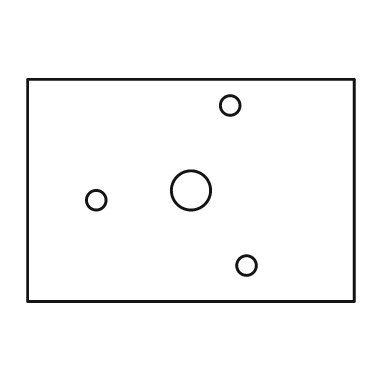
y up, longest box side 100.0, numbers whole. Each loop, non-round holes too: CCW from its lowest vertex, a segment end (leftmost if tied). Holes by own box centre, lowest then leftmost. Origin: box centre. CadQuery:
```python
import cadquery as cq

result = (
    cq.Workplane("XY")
    .moveTo(-50.0, -34.0)
    .lineTo(50.0, -34.0)
    .lineTo(50.0, 34.0)
    .lineTo(-50.0, 34.0)
    .close()
    .moveTo(17.0, -23.0)
    .circle(3.0)
    .moveTo(-29.0, -3.0)
    .circle(3.0)
    .moveTo(0.0, 0.0)
    .circle(6.0)
    .moveTo(12.0, 26.0)
    .circle(3.0)
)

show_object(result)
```